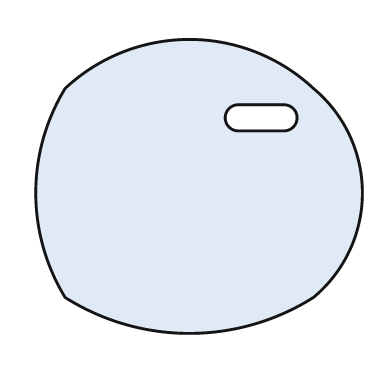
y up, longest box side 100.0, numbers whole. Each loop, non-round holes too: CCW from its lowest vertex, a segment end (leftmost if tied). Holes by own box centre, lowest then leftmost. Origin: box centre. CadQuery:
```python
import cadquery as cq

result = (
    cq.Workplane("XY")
    .moveTo(-41.0, -34.0)
    .threePointArc((-3.0, -45.0), (35.0, -34.0))
    .threePointArc((50.0, -2.0), (35.0, 30.0))
    .threePointArc((-3.0, 45.0), (-41.0, 30.0))
    .threePointArc((-50.0, -2.0), (-41.0, -34.0))
    .close()
    .moveTo(12.0, 17.0)
    .lineTo(26.0, 17.0)
    .threePointArc((30.0, 21.0), (26.0, 25.0))
    .lineTo(12.0, 25.0)
    .threePointArc((8.0, 21.0), (12.0, 17.0))
    .close()
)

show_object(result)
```